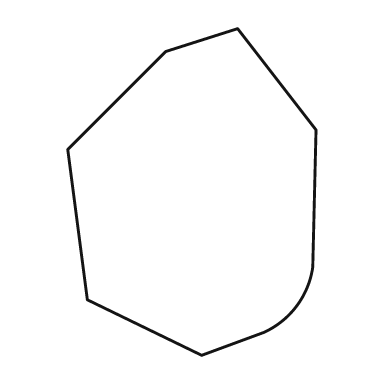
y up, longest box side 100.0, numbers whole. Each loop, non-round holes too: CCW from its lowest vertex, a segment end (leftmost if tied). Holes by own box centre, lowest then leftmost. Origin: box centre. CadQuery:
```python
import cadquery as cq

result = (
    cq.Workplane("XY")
    .moveTo(3.0, -50.0)
    .lineTo(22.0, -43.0)
    .threePointArc((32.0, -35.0), (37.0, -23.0))
    .lineTo(38.0, 19.0)
    .lineTo(14.0, 50.0)
    .lineTo(-8.0, 43.0)
    .lineTo(-38.0, 13.0)
    .lineTo(-32.0, -33.0)
    .close()
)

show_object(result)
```